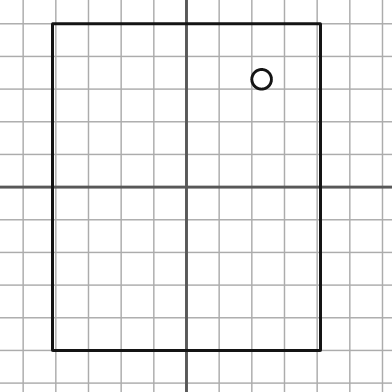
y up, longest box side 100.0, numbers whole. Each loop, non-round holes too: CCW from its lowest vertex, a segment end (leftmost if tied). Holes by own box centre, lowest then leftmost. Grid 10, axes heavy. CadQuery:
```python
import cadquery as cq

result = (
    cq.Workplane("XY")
    .moveTo(-41.0, -50.0)
    .lineTo(41.0, -50.0)
    .lineTo(41.0, 50.0)
    .lineTo(-41.0, 50.0)
    .close()
    .moveTo(23.0, 33.0)
    .circle(3.0)
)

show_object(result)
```